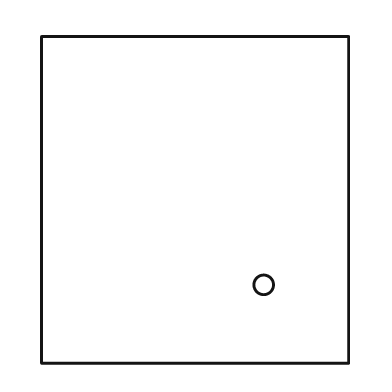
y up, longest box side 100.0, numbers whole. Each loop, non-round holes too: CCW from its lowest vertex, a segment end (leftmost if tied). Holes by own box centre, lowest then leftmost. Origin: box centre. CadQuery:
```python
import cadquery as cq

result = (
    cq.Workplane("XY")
    .moveTo(-47.0, -50.0)
    .lineTo(47.0, -50.0)
    .lineTo(47.0, 50.0)
    .lineTo(-47.0, 50.0)
    .close()
    .moveTo(21.0, -26.0)
    .circle(3.0)
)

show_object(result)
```